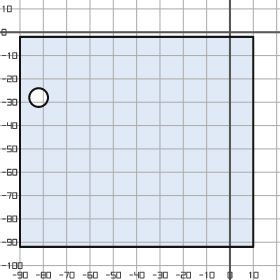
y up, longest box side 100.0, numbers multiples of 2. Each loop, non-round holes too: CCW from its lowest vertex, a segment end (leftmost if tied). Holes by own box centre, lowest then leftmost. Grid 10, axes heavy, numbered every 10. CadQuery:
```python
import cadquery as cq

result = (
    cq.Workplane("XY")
    .moveTo(-90.0, -92.0)
    .lineTo(10.0, -92.0)
    .lineTo(10.0, -2.0)
    .lineTo(-90.0, -2.0)
    .close()
    .moveTo(-82.0, -28.0)
    .circle(4.0)
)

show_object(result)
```